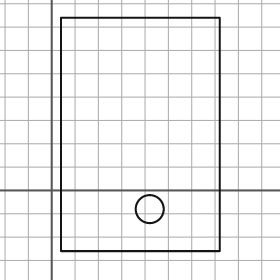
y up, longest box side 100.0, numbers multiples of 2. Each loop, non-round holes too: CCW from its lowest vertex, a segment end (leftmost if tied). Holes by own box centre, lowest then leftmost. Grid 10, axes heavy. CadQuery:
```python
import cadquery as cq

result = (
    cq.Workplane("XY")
    .moveTo(4.0, -26.0)
    .lineTo(72.0, -26.0)
    .lineTo(72.0, 74.0)
    .lineTo(4.0, 74.0)
    .close()
    .moveTo(42.0, -8.0)
    .circle(6.0)
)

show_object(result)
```